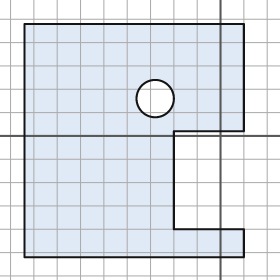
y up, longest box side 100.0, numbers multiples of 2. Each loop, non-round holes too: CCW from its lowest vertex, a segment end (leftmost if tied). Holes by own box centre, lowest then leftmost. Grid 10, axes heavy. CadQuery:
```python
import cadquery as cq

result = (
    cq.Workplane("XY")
    .moveTo(-84.0, -52.0)
    .lineTo(10.0, -52.0)
    .lineTo(10.0, -40.0)
    .lineTo(-20.0, -40.0)
    .lineTo(-20.0, 2.0)
    .lineTo(10.0, 2.0)
    .lineTo(10.0, 48.0)
    .lineTo(-84.0, 48.0)
    .close()
    .moveTo(-28.0, 16.0)
    .circle(8.0)
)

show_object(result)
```